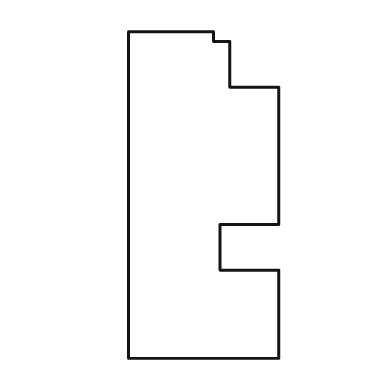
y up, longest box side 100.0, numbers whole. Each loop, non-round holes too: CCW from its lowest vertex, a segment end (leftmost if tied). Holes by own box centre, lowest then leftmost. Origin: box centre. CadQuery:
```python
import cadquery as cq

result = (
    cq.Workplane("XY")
    .moveTo(-23.0, -50.0)
    .lineTo(23.0, -50.0)
    .lineTo(23.0, -23.0)
    .lineTo(5.0, -23.0)
    .lineTo(5.0, -9.0)
    .lineTo(23.0, -9.0)
    .lineTo(23.0, 33.0)
    .lineTo(8.0, 33.0)
    .lineTo(8.0, 47.0)
    .lineTo(3.0, 47.0)
    .lineTo(3.0, 50.0)
    .lineTo(-23.0, 50.0)
    .close()
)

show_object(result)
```